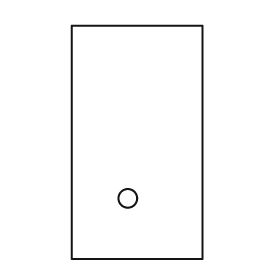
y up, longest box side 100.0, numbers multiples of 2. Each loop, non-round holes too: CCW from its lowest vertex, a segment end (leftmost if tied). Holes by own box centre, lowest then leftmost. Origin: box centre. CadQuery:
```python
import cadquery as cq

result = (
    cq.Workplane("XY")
    .moveTo(-28.0, -50.0)
    .lineTo(28.0, -50.0)
    .lineTo(28.0, 50.0)
    .lineTo(-28.0, 50.0)
    .close()
    .moveTo(-4.0, -24.0)
    .circle(4.0)
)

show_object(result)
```